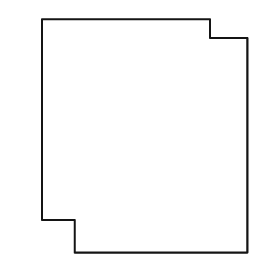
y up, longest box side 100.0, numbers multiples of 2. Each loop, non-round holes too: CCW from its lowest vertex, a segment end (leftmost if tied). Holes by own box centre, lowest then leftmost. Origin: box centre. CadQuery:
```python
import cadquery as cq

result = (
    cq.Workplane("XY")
    .moveTo(-30.0, -50.0)
    .lineTo(44.0, -50.0)
    .lineTo(44.0, 42.0)
    .lineTo(28.0, 42.0)
    .lineTo(28.0, 50.0)
    .lineTo(-44.0, 50.0)
    .lineTo(-44.0, -36.0)
    .lineTo(-30.0, -36.0)
    .close()
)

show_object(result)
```